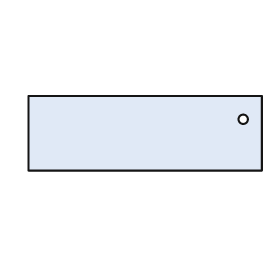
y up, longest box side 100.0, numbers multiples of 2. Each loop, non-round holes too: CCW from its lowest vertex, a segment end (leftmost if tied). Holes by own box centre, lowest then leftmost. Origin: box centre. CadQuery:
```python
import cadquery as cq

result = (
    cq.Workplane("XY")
    .moveTo(-50.0, -16.0)
    .lineTo(50.0, -16.0)
    .lineTo(50.0, 16.0)
    .lineTo(-50.0, 16.0)
    .close()
    .moveTo(42.0, 6.0)
    .circle(2.0)
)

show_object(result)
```